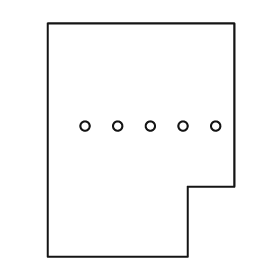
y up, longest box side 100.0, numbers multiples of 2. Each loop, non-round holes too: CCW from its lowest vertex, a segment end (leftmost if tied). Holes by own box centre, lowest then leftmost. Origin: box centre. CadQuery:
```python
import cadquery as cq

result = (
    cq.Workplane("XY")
    .moveTo(-40.0, -50.0)
    .lineTo(20.0, -50.0)
    .lineTo(20.0, -20.0)
    .lineTo(40.0, -20.0)
    .lineTo(40.0, 50.0)
    .lineTo(-40.0, 50.0)
    .close()
    .moveTo(-24.0, 6.0)
    .circle(2.0)
    .moveTo(-10.0, 6.0)
    .circle(2.0)
    .moveTo(4.0, 6.0)
    .circle(2.0)
    .moveTo(18.0, 6.0)
    .circle(2.0)
    .moveTo(32.0, 6.0)
    .circle(2.0)
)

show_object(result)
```